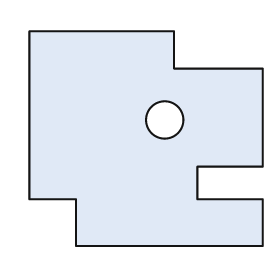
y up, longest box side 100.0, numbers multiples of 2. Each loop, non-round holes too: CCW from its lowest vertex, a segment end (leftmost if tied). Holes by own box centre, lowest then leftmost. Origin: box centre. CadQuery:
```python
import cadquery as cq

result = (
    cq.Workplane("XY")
    .moveTo(-30.0, -46.0)
    .lineTo(50.0, -46.0)
    .lineTo(50.0, -26.0)
    .lineTo(22.0, -26.0)
    .lineTo(22.0, -12.0)
    .lineTo(50.0, -12.0)
    .lineTo(50.0, 30.0)
    .lineTo(12.0, 30.0)
    .lineTo(12.0, 46.0)
    .lineTo(-50.0, 46.0)
    .lineTo(-50.0, -26.0)
    .lineTo(-30.0, -26.0)
    .close()
    .moveTo(8.0, 8.0)
    .circle(8.0)
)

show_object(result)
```